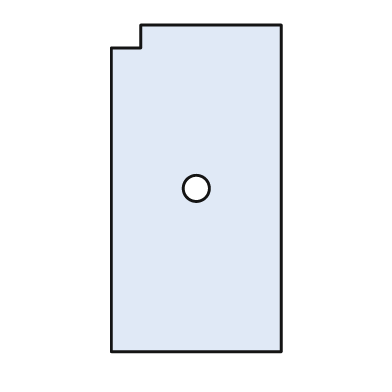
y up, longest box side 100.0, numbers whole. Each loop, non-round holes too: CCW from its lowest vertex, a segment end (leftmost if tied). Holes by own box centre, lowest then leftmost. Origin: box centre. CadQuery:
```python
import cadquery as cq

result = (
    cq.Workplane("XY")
    .moveTo(-26.0, -50.0)
    .lineTo(26.0, -50.0)
    .lineTo(26.0, 50.0)
    .lineTo(-17.0, 50.0)
    .lineTo(-17.0, 43.0)
    .lineTo(-26.0, 43.0)
    .close()
    .moveTo(0.0, 0.0)
    .circle(4.0)
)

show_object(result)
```